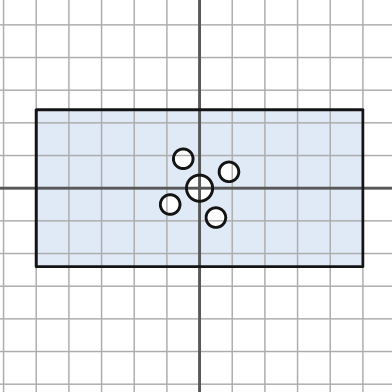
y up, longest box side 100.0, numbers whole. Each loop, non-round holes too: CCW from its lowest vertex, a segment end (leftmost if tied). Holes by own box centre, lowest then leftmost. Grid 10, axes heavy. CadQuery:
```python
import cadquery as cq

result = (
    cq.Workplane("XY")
    .moveTo(-50.0, -24.0)
    .lineTo(50.0, -24.0)
    .lineTo(50.0, 24.0)
    .lineTo(-50.0, 24.0)
    .close()
    .moveTo(5.0, -9.0)
    .circle(3.0)
    .moveTo(-9.0, -5.0)
    .circle(3.0)
    .moveTo(0.0, 0.0)
    .circle(4.0)
    .moveTo(9.0, 5.0)
    .circle(3.0)
    .moveTo(-5.0, 9.0)
    .circle(3.0)
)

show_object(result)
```